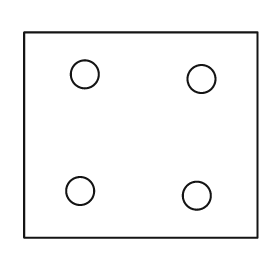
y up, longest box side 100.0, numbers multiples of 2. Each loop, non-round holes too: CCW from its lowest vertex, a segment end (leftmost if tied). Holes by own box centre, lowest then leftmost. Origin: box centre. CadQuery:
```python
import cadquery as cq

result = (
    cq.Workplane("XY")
    .moveTo(-50.0, -44.0)
    .lineTo(50.0, -44.0)
    .lineTo(50.0, 44.0)
    .lineTo(-50.0, 44.0)
    .close()
    .moveTo(24.0, -26.0)
    .circle(6.0)
    .moveTo(-26.0, -24.0)
    .circle(6.0)
    .moveTo(26.0, 24.0)
    .circle(6.0)
    .moveTo(-24.0, 26.0)
    .circle(6.0)
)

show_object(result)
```